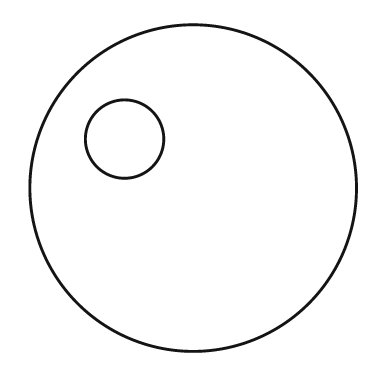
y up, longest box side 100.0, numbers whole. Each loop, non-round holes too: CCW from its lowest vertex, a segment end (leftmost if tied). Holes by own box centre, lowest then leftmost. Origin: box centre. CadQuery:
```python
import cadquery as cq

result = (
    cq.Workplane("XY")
    .moveTo(0.0, 0.0)
    .circle(50.0)
    .moveTo(-21.0, 15.0)
    .circle(12.0)
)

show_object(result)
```